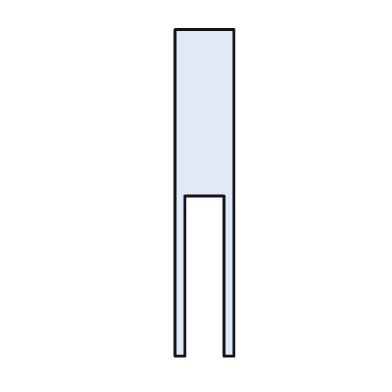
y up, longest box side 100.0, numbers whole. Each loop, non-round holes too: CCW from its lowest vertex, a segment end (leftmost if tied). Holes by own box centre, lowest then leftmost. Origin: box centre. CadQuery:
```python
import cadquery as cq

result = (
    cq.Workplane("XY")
    .moveTo(-9.0, -50.0)
    .lineTo(-6.0, -50.0)
    .lineTo(-6.0, -1.0)
    .lineTo(6.0, -1.0)
    .lineTo(6.0, -50.0)
    .lineTo(9.0, -50.0)
    .lineTo(9.0, 50.0)
    .lineTo(-9.0, 50.0)
    .close()
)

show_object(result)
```